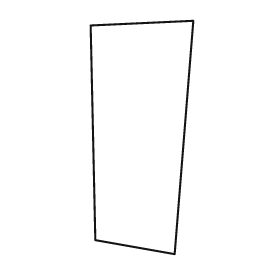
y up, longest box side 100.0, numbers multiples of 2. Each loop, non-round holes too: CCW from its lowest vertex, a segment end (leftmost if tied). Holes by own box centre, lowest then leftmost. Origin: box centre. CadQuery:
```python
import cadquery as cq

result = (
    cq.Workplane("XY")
    .moveTo(14.0, -50.0)
    .lineTo(22.0, 50.0)
    .lineTo(-22.0, 48.0)
    .lineTo(-20.0, -44.0)
    .close()
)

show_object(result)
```